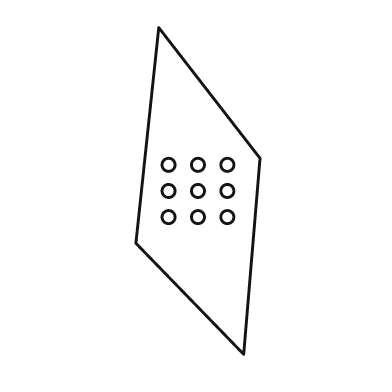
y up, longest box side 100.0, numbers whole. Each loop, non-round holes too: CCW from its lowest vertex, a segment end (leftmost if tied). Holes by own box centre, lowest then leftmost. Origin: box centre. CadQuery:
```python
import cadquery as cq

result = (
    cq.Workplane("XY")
    .moveTo(14.0, -50.0)
    .lineTo(19.0, 10.0)
    .lineTo(-12.0, 50.0)
    .lineTo(-19.0, -16.0)
    .close()
    .moveTo(-9.0, -8.0)
    .circle(2.0)
    .moveTo(0.0, -8.0)
    .circle(2.0)
    .moveTo(9.0, -8.0)
    .circle(2.0)
    .moveTo(-9.0, 0.0)
    .circle(2.0)
    .moveTo(0.0, 0.0)
    .circle(2.0)
    .moveTo(9.0, 0.0)
    .circle(2.0)
    .moveTo(-9.0, 8.0)
    .circle(2.0)
    .moveTo(0.0, 8.0)
    .circle(2.0)
    .moveTo(9.0, 8.0)
    .circle(2.0)
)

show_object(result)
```